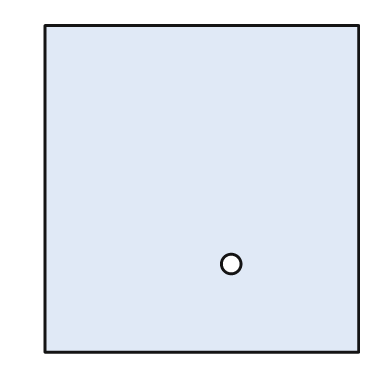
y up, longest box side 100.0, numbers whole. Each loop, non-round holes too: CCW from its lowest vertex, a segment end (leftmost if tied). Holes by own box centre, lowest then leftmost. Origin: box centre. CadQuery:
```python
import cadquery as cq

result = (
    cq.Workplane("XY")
    .moveTo(-48.0, -50.0)
    .lineTo(48.0, -50.0)
    .lineTo(48.0, 50.0)
    .lineTo(-48.0, 50.0)
    .close()
    .moveTo(9.0, -23.0)
    .circle(3.0)
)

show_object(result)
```